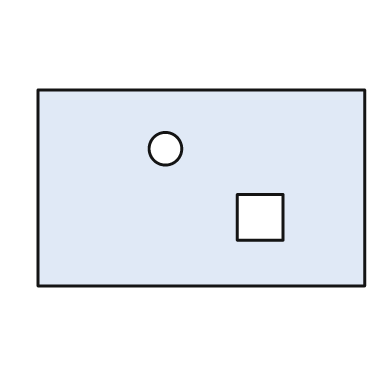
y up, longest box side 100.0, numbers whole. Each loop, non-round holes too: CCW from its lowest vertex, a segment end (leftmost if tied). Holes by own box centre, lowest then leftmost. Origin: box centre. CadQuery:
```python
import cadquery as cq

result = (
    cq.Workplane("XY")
    .moveTo(-50.0, -30.0)
    .lineTo(50.0, -30.0)
    .lineTo(50.0, 30.0)
    .lineTo(-50.0, 30.0)
    .close()
    .moveTo(11.0, -16.0)
    .lineTo(25.0, -16.0)
    .lineTo(25.0, -2.0)
    .lineTo(11.0, -2.0)
    .close()
    .moveTo(-11.0, 12.0)
    .circle(5.0)
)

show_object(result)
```